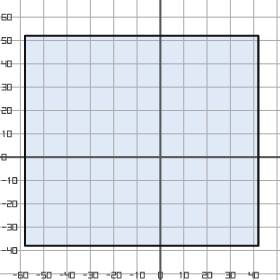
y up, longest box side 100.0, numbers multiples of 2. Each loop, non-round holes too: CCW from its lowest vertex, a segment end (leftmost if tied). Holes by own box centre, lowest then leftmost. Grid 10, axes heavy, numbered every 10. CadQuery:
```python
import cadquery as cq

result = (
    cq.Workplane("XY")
    .moveTo(-58.0, -38.0)
    .lineTo(42.0, -38.0)
    .lineTo(42.0, 52.0)
    .lineTo(-58.0, 52.0)
    .close()
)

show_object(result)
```